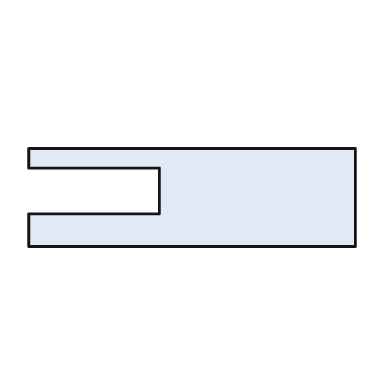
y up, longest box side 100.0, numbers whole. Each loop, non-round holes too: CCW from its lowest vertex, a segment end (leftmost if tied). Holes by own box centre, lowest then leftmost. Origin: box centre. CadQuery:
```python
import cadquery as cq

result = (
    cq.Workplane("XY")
    .moveTo(-50.0, -15.0)
    .lineTo(50.0, -15.0)
    .lineTo(50.0, 15.0)
    .lineTo(-50.0, 15.0)
    .lineTo(-50.0, 9.0)
    .lineTo(-10.0, 9.0)
    .lineTo(-10.0, -5.0)
    .lineTo(-50.0, -5.0)
    .close()
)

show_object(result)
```